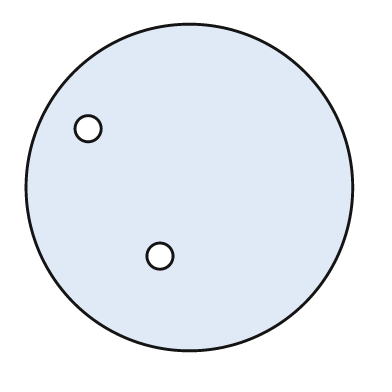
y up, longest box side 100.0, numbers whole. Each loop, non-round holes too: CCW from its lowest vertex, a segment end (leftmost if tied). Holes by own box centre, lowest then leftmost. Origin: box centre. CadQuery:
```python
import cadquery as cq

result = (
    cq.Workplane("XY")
    .moveTo(0.0, 0.0)
    .circle(50.0)
    .moveTo(-9.0, -21.0)
    .circle(4.0)
    .moveTo(-31.0, 18.0)
    .circle(4.0)
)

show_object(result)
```